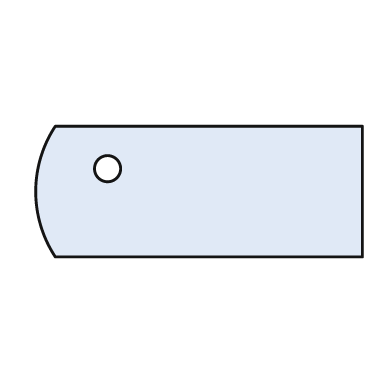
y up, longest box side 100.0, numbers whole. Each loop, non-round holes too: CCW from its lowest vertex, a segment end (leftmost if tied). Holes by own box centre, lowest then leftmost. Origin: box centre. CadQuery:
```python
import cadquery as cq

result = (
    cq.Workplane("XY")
    .moveTo(-44.0, -20.0)
    .lineTo(50.0, -20.0)
    .lineTo(50.0, 20.0)
    .lineTo(-44.0, 20.0)
    .threePointArc((-50.0, 0.0), (-44.0, -20.0))
    .close()
    .moveTo(-28.0, 7.0)
    .circle(4.0)
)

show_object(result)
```